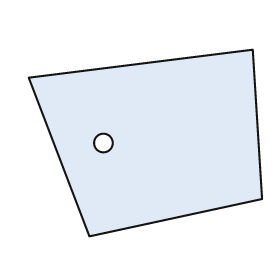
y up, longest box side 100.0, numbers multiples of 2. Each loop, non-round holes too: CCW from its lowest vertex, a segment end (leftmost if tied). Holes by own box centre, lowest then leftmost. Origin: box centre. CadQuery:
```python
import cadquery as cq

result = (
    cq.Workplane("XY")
    .moveTo(-24.0, -40.0)
    .lineTo(50.0, -24.0)
    .lineTo(46.0, 40.0)
    .lineTo(-50.0, 28.0)
    .close()
    .moveTo(-18.0, 0.0)
    .circle(4.0)
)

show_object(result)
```